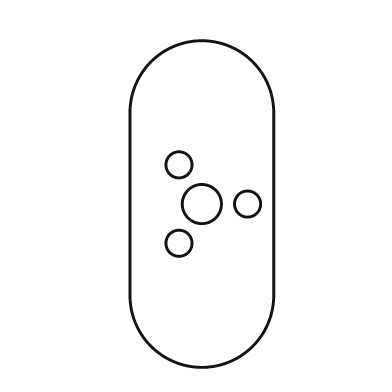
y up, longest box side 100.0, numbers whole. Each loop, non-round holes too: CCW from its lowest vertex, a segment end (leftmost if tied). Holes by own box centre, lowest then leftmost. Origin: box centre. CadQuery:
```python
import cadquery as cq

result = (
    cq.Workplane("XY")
    .moveTo(-22.0, -28.0)
    .threePointArc((0.0, -50.0), (22.0, -28.0))
    .lineTo(22.0, 28.0)
    .threePointArc((0.0, 50.0), (-22.0, 28.0))
    .close()
    .moveTo(-7.0, -12.0)
    .circle(4.0)
    .moveTo(0.0, 0.0)
    .circle(6.0)
    .moveTo(14.0, 0.0)
    .circle(4.0)
    .moveTo(-7.0, 12.0)
    .circle(4.0)
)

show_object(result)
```